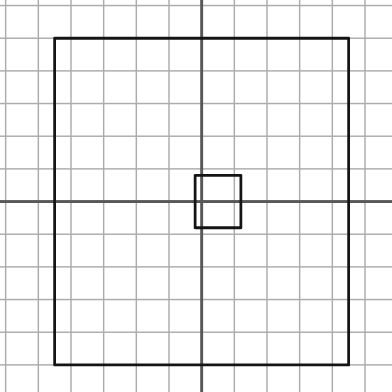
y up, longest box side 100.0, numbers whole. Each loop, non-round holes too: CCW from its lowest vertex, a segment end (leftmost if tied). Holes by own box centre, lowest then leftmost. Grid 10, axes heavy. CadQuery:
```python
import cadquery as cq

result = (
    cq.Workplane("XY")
    .moveTo(-45.0, -50.0)
    .lineTo(45.0, -50.0)
    .lineTo(45.0, 50.0)
    .lineTo(-45.0, 50.0)
    .close()
    .moveTo(-2.0, -8.0)
    .lineTo(12.0, -8.0)
    .lineTo(12.0, 8.0)
    .lineTo(-2.0, 8.0)
    .close()
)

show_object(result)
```